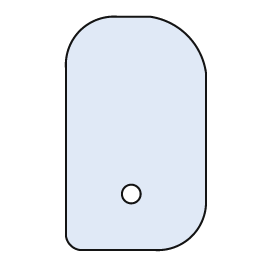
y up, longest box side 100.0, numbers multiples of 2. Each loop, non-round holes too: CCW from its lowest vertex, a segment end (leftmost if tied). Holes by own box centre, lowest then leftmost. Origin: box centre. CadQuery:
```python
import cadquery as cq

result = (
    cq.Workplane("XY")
    .moveTo(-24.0, -50.0)
    .lineTo(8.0, -50.0)
    .threePointArc((24.0, -44.0), (30.0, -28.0))
    .lineTo(30.0, 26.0)
    .threePointArc((22.0, 42.0), (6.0, 50.0))
    .lineTo(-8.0, 50.0)
    .threePointArc((-24.0, 44.0), (-30.0, 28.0))
    .lineTo(-30.0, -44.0)
    .threePointArc((-28.0, -48.0), (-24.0, -50.0))
    .close()
    .moveTo(-2.0, -26.0)
    .circle(4.0)
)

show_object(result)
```